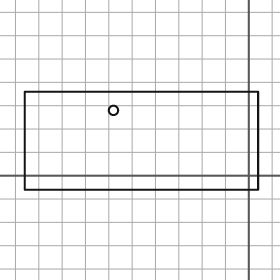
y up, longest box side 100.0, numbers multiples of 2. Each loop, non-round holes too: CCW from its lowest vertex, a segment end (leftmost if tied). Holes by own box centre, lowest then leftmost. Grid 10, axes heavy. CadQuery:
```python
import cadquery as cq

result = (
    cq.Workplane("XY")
    .moveTo(-96.0, -6.0)
    .lineTo(4.0, -6.0)
    .lineTo(4.0, 36.0)
    .lineTo(-96.0, 36.0)
    .close()
    .moveTo(-58.0, 28.0)
    .circle(2.0)
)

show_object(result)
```